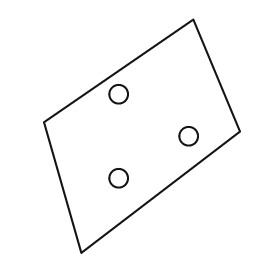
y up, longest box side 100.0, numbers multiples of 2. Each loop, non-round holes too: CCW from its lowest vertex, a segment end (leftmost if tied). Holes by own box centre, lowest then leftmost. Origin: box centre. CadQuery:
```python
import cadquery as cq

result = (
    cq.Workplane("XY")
    .moveTo(-26.0, -50.0)
    .lineTo(42.0, 2.0)
    .lineTo(22.0, 50.0)
    .lineTo(-42.0, 6.0)
    .close()
    .moveTo(-10.0, -18.0)
    .circle(4.0)
    .moveTo(20.0, 0.0)
    .circle(4.0)
    .moveTo(-10.0, 18.0)
    .circle(4.0)
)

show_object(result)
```